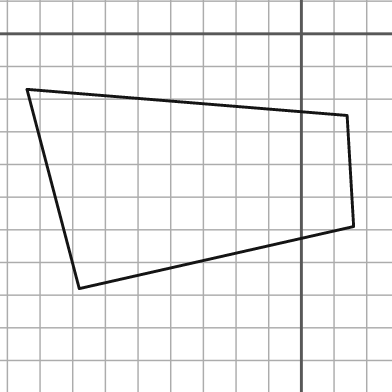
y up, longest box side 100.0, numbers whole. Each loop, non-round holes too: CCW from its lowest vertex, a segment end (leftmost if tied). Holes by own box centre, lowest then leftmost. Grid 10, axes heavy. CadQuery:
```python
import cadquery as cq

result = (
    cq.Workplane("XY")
    .moveTo(-68.0, -78.0)
    .lineTo(16.0, -59.0)
    .lineTo(14.0, -25.0)
    .lineTo(-84.0, -17.0)
    .close()
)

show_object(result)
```